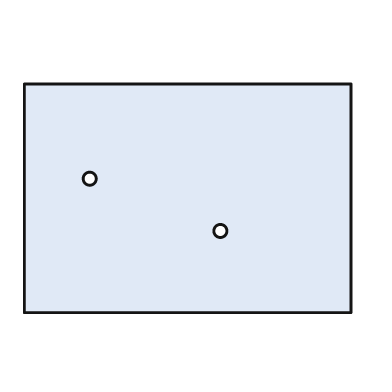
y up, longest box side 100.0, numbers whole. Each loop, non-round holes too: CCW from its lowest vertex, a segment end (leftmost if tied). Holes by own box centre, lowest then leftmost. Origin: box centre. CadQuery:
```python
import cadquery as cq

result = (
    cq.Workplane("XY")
    .moveTo(-50.0, -35.0)
    .lineTo(50.0, -35.0)
    .lineTo(50.0, 35.0)
    .lineTo(-50.0, 35.0)
    .close()
    .moveTo(10.0, -10.0)
    .circle(2.0)
    .moveTo(-30.0, 6.0)
    .circle(2.0)
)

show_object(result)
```